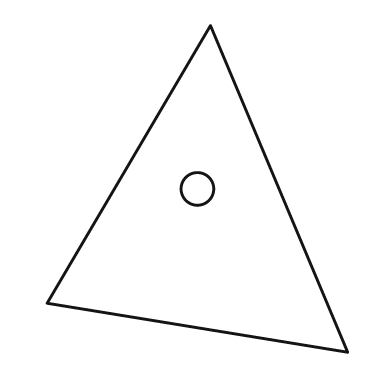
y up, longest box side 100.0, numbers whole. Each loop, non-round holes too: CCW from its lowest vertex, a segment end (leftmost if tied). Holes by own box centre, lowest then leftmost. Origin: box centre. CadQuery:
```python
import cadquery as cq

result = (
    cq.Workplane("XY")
    .moveTo(46.0, -50.0)
    .lineTo(4.0, 50.0)
    .lineTo(-46.0, -35.0)
    .close()
    .moveTo(0.0, 0.0)
    .circle(5.0)
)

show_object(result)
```